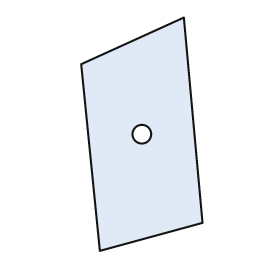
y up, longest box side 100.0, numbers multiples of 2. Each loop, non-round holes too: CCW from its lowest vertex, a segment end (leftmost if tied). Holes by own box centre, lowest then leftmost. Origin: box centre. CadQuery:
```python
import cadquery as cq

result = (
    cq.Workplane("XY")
    .moveTo(-18.0, -50.0)
    .lineTo(26.0, -38.0)
    .lineTo(18.0, 50.0)
    .lineTo(-26.0, 30.0)
    .close()
    .moveTo(0.0, 0.0)
    .circle(4.0)
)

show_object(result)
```